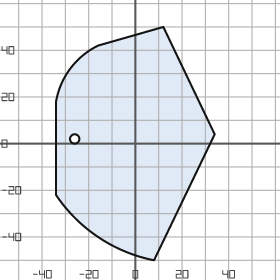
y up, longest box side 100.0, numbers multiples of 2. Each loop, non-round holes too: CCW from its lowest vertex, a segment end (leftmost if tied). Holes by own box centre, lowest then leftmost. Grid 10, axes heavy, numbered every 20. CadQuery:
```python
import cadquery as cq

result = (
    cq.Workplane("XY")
    .moveTo(8.0, -50.0)
    .lineTo(34.0, 4.0)
    .lineTo(12.0, 50.0)
    .lineTo(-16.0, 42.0)
    .threePointArc((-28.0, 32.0), (-34.0, 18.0))
    .lineTo(-34.0, -22.0)
    .threePointArc((-16.0, -40.0), (8.0, -50.0))
    .close()
    .moveTo(-26.0, 2.0)
    .circle(2.0)
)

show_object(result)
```